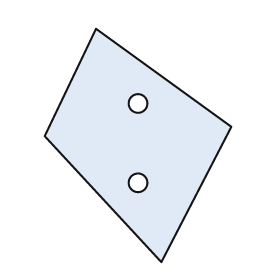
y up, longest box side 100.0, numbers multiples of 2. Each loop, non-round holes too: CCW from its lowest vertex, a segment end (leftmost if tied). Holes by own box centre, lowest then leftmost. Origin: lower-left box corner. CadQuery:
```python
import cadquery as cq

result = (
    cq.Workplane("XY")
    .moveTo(50.0, 0.0)
    .lineTo(80.0, 58.0)
    .lineTo(22.0, 100.0)
    .lineTo(0.0, 54.0)
    .close()
    .moveTo(40.0, 34.0)
    .circle(4.0)
    .moveTo(40.0, 68.0)
    .circle(4.0)
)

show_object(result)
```